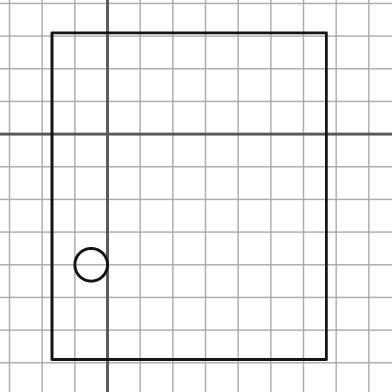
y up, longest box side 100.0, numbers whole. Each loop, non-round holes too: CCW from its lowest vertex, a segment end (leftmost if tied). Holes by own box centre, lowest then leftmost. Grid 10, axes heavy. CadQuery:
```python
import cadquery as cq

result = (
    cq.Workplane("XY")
    .moveTo(-17.0, -69.0)
    .lineTo(67.0, -69.0)
    .lineTo(67.0, 31.0)
    .lineTo(-17.0, 31.0)
    .close()
    .moveTo(-5.0, -40.0)
    .circle(5.0)
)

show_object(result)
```